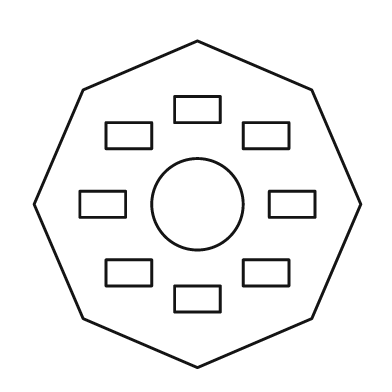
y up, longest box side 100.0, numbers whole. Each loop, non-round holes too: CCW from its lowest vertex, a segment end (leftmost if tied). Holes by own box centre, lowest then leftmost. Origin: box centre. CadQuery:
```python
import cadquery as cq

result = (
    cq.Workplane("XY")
    .moveTo(0.0, -50.0)
    .lineTo(35.0, -35.0)
    .lineTo(50.0, 0.0)
    .lineTo(35.0, 35.0)
    .lineTo(0.0, 50.0)
    .lineTo(-35.0, 35.0)
    .lineTo(-50.0, 0.0)
    .lineTo(-35.0, -35.0)
    .close()
    .moveTo(-7.0, -33.0)
    .lineTo(7.0, -33.0)
    .lineTo(7.0, -25.0)
    .lineTo(-7.0, -25.0)
    .close()
    .moveTo(-28.0, -25.0)
    .lineTo(-14.0, -25.0)
    .lineTo(-14.0, -17.0)
    .lineTo(-28.0, -17.0)
    .close()
    .moveTo(14.0, -25.0)
    .lineTo(28.0, -25.0)
    .lineTo(28.0, -17.0)
    .lineTo(14.0, -17.0)
    .close()
    .moveTo(-36.0, -4.0)
    .lineTo(-22.0, -4.0)
    .lineTo(-22.0, 4.0)
    .lineTo(-36.0, 4.0)
    .close()
    .moveTo(0.0, 0.0)
    .circle(14.0)
    .moveTo(22.0, -4.0)
    .lineTo(36.0, -4.0)
    .lineTo(36.0, 4.0)
    .lineTo(22.0, 4.0)
    .close()
    .moveTo(-28.0, 17.0)
    .lineTo(-14.0, 17.0)
    .lineTo(-14.0, 25.0)
    .lineTo(-28.0, 25.0)
    .close()
    .moveTo(14.0, 17.0)
    .lineTo(28.0, 17.0)
    .lineTo(28.0, 25.0)
    .lineTo(14.0, 25.0)
    .close()
    .moveTo(-7.0, 25.0)
    .lineTo(7.0, 25.0)
    .lineTo(7.0, 33.0)
    .lineTo(-7.0, 33.0)
    .close()
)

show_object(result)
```